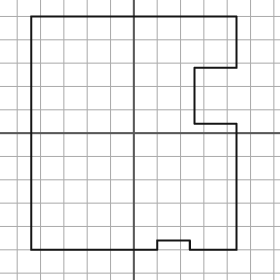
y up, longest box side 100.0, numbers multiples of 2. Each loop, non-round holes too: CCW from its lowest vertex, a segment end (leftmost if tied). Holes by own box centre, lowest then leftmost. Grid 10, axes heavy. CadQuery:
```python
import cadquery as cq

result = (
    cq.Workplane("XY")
    .moveTo(-44.0, -50.0)
    .lineTo(10.0, -50.0)
    .lineTo(10.0, -46.0)
    .lineTo(24.0, -46.0)
    .lineTo(24.0, -50.0)
    .lineTo(44.0, -50.0)
    .lineTo(44.0, 4.0)
    .lineTo(26.0, 4.0)
    .lineTo(26.0, 28.0)
    .lineTo(44.0, 28.0)
    .lineTo(44.0, 50.0)
    .lineTo(-44.0, 50.0)
    .close()
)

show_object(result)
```